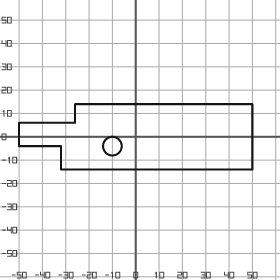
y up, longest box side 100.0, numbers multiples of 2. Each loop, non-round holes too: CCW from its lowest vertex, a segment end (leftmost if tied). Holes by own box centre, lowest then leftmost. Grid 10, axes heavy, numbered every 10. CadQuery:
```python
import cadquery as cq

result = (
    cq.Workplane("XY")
    .moveTo(-32.0, -14.0)
    .lineTo(50.0, -14.0)
    .lineTo(50.0, 14.0)
    .lineTo(-26.0, 14.0)
    .lineTo(-26.0, 6.0)
    .lineTo(-50.0, 6.0)
    .lineTo(-50.0, -4.0)
    .lineTo(-32.0, -4.0)
    .close()
    .moveTo(-10.0, -4.0)
    .circle(4.0)
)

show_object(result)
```